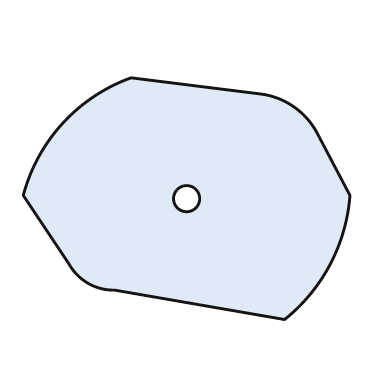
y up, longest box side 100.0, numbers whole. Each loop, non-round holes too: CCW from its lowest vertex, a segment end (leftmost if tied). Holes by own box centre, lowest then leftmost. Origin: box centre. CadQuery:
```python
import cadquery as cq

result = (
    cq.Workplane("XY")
    .moveTo(30.0, -37.0)
    .threePointArc((44.0, -20.0), (50.0, 1.0))
    .lineTo(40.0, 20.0)
    .threePointArc((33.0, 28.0), (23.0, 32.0))
    .lineTo(-17.0, 37.0)
    .threePointArc((-38.0, 23.0), (-50.0, 1.0))
    .lineTo(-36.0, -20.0)
    .threePointArc((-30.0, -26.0), (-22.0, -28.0))
    .close()
    .moveTo(0.0, 0.0)
    .circle(4.0)
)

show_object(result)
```